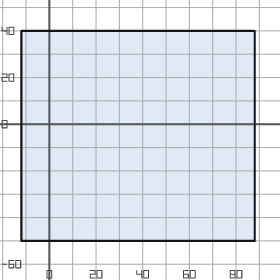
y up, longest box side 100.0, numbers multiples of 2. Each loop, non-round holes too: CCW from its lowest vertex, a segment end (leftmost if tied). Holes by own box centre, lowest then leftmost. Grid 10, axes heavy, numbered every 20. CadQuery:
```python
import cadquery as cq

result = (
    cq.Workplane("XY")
    .moveTo(-12.0, -50.0)
    .lineTo(88.0, -50.0)
    .lineTo(88.0, 40.0)
    .lineTo(-12.0, 40.0)
    .close()
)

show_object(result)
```